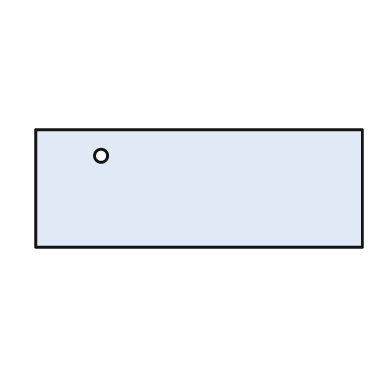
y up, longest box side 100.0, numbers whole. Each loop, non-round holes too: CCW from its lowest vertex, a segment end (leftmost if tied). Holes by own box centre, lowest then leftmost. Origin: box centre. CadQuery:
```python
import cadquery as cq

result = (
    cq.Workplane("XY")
    .moveTo(-50.0, -18.0)
    .lineTo(50.0, -18.0)
    .lineTo(50.0, 18.0)
    .lineTo(-50.0, 18.0)
    .close()
    .moveTo(-30.0, 10.0)
    .circle(2.0)
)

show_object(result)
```